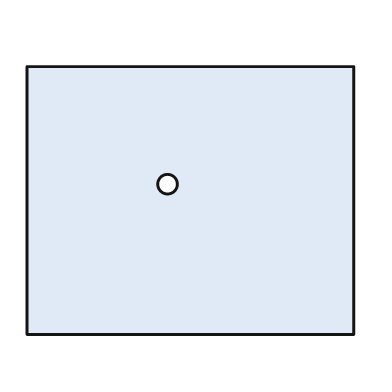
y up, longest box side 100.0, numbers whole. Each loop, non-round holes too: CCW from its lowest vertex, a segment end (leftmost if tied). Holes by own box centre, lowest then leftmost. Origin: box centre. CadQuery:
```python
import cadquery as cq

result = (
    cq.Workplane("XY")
    .moveTo(-50.0, -41.0)
    .lineTo(50.0, -41.0)
    .lineTo(50.0, 41.0)
    .lineTo(-50.0, 41.0)
    .close()
    .moveTo(-7.0, 5.0)
    .circle(3.0)
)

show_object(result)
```